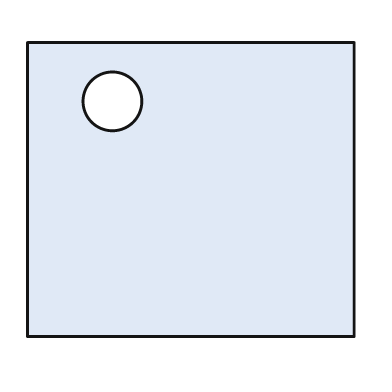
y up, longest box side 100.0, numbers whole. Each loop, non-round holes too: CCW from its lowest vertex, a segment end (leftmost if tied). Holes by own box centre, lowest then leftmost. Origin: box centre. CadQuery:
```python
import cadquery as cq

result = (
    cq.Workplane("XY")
    .moveTo(-50.0, -45.0)
    .lineTo(50.0, -45.0)
    .lineTo(50.0, 45.0)
    .lineTo(-50.0, 45.0)
    .close()
    .moveTo(-24.0, 27.0)
    .circle(9.0)
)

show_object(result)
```